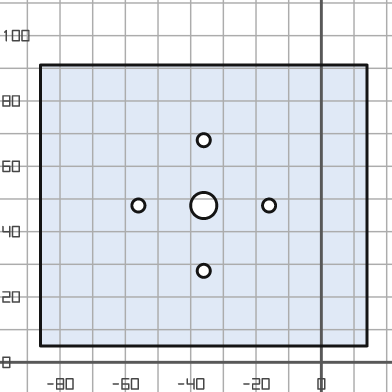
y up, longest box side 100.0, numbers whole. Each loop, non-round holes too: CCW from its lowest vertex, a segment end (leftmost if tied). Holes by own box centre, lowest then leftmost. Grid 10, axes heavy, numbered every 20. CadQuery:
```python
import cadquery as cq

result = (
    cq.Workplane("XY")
    .moveTo(-86.0, 5.0)
    .lineTo(14.0, 5.0)
    .lineTo(14.0, 91.0)
    .lineTo(-86.0, 91.0)
    .close()
    .moveTo(-36.0, 28.0)
    .circle(2.0)
    .moveTo(-56.0, 48.0)
    .circle(2.0)
    .moveTo(-36.0, 48.0)
    .circle(4.0)
    .moveTo(-16.0, 48.0)
    .circle(2.0)
    .moveTo(-36.0, 68.0)
    .circle(2.0)
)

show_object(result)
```